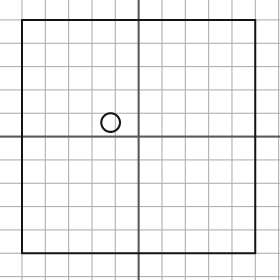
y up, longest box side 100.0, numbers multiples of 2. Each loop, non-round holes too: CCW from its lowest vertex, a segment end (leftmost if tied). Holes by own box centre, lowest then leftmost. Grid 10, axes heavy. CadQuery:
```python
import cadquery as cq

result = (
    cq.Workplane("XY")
    .moveTo(-50.0, -50.0)
    .lineTo(50.0, -50.0)
    .lineTo(50.0, 50.0)
    .lineTo(-50.0, 50.0)
    .close()
    .moveTo(-12.0, 6.0)
    .circle(4.0)
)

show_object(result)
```